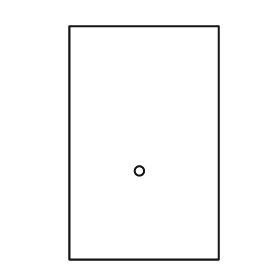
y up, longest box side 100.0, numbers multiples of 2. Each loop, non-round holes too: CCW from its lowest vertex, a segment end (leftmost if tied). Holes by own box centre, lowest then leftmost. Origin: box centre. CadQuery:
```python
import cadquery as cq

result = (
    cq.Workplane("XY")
    .moveTo(-32.0, -50.0)
    .lineTo(32.0, -50.0)
    .lineTo(32.0, 50.0)
    .lineTo(-32.0, 50.0)
    .close()
    .moveTo(-2.0, -12.0)
    .circle(2.0)
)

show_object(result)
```